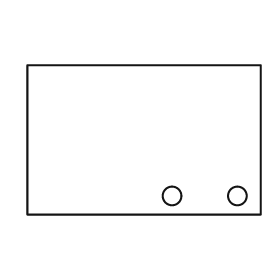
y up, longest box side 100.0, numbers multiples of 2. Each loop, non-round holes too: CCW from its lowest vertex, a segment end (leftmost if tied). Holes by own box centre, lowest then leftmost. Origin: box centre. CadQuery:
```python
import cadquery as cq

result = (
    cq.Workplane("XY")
    .moveTo(-50.0, -32.0)
    .lineTo(50.0, -32.0)
    .lineTo(50.0, 32.0)
    .lineTo(-50.0, 32.0)
    .close()
    .moveTo(12.0, -24.0)
    .circle(4.0)
    .moveTo(40.0, -24.0)
    .circle(4.0)
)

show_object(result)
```